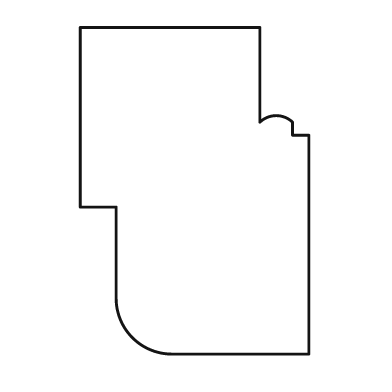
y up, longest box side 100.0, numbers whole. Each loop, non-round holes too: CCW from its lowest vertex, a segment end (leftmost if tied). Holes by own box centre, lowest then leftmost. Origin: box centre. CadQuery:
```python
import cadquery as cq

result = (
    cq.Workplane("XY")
    .moveTo(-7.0, -50.0)
    .lineTo(35.0, -50.0)
    .lineTo(35.0, 17.0)
    .lineTo(30.0, 17.0)
    .lineTo(30.0, 21.0)
    .threePointArc((25.0, 23.0), (20.0, 21.0))
    .lineTo(20.0, 50.0)
    .lineTo(-35.0, 50.0)
    .lineTo(-35.0, -5.0)
    .lineTo(-24.0, -5.0)
    .lineTo(-24.0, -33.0)
    .threePointArc((-19.0, -45.0), (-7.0, -50.0))
    .close()
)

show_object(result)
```